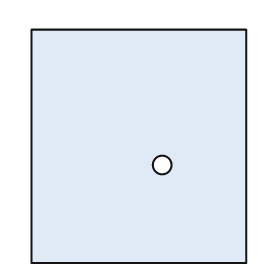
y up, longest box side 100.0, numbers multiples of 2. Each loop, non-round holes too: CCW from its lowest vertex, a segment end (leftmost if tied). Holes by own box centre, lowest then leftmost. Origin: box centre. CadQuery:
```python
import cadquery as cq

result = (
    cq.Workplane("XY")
    .moveTo(-46.0, -50.0)
    .lineTo(46.0, -50.0)
    .lineTo(46.0, 50.0)
    .lineTo(-46.0, 50.0)
    .close()
    .moveTo(10.0, -8.0)
    .circle(4.0)
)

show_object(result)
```